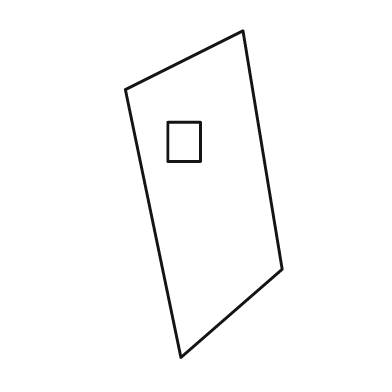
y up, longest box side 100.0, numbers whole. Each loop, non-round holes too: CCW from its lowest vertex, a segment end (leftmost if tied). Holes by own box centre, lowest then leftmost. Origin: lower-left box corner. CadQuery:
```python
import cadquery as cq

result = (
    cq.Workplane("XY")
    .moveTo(17.0, 0.0)
    .lineTo(48.0, 27.0)
    .lineTo(36.0, 100.0)
    .lineTo(0.0, 82.0)
    .close()
    .moveTo(13.0, 60.0)
    .lineTo(23.0, 60.0)
    .lineTo(23.0, 72.0)
    .lineTo(13.0, 72.0)
    .close()
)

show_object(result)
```